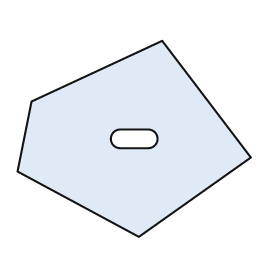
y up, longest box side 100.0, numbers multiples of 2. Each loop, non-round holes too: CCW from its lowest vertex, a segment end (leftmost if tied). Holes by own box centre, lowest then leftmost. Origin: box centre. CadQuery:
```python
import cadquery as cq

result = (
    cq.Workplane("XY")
    .moveTo(2.0, -42.0)
    .lineTo(50.0, -8.0)
    .lineTo(12.0, 42.0)
    .lineTo(-44.0, 16.0)
    .lineTo(-50.0, -14.0)
    .close()
    .moveTo(-6.0, -4.0)
    .lineTo(6.0, -4.0)
    .threePointArc((10.0, 0.0), (6.0, 4.0))
    .lineTo(-6.0, 4.0)
    .threePointArc((-10.0, 0.0), (-6.0, -4.0))
    .close()
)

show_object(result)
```